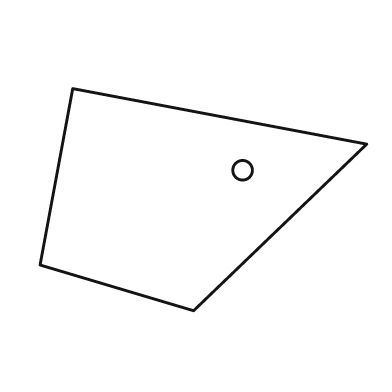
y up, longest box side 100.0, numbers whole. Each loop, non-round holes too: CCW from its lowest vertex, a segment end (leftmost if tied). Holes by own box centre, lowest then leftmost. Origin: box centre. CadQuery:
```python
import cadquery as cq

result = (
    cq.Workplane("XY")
    .moveTo(-3.0, -34.0)
    .lineTo(50.0, 17.0)
    .lineTo(-40.0, 34.0)
    .lineTo(-50.0, -20.0)
    .close()
    .moveTo(12.0, 9.0)
    .circle(3.0)
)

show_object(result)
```